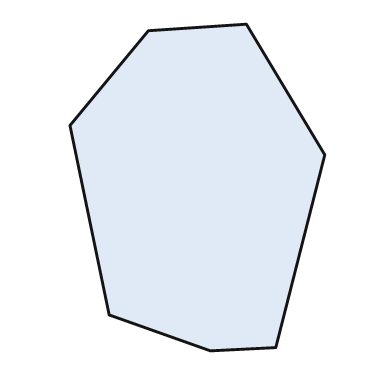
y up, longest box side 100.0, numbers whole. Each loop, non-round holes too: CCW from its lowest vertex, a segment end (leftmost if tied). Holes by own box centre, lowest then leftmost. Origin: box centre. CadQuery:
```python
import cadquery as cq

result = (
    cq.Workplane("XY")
    .moveTo(4.0, -50.0)
    .lineTo(24.0, -49.0)
    .lineTo(39.0, 10.0)
    .lineTo(15.0, 50.0)
    .lineTo(-15.0, 48.0)
    .lineTo(-39.0, 19.0)
    .lineTo(-27.0, -39.0)
    .close()
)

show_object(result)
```